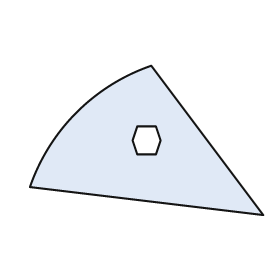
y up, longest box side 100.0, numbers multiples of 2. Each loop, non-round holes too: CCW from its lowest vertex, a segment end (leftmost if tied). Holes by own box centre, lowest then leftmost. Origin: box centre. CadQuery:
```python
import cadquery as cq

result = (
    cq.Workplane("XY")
    .moveTo(50.0, -32.0)
    .lineTo(2.0, 32.0)
    .threePointArc((-30.0, 12.0), (-50.0, -20.0))
    .close()
    .moveTo(-4.0, -6.0)
    .lineTo(4.0, -6.0)
    .lineTo(6.0, 0.0)
    .lineTo(4.0, 6.0)
    .lineTo(-4.0, 6.0)
    .lineTo(-6.0, 0.0)
    .close()
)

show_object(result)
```